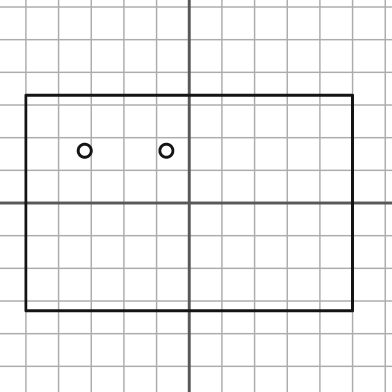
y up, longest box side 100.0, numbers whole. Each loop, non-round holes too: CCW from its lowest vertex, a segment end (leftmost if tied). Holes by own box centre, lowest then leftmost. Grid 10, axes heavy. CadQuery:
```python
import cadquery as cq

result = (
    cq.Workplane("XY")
    .moveTo(-50.0, -33.0)
    .lineTo(50.0, -33.0)
    .lineTo(50.0, 33.0)
    .lineTo(-50.0, 33.0)
    .close()
    .moveTo(-32.0, 16.0)
    .circle(2.0)
    .moveTo(-7.0, 16.0)
    .circle(2.0)
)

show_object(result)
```